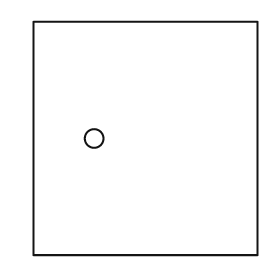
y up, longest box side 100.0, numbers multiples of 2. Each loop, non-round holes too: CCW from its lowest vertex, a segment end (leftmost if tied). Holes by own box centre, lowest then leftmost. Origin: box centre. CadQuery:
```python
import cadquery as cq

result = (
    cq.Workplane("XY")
    .moveTo(-48.0, -50.0)
    .lineTo(48.0, -50.0)
    .lineTo(48.0, 50.0)
    .lineTo(-48.0, 50.0)
    .close()
    .moveTo(-22.0, 0.0)
    .circle(4.0)
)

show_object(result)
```